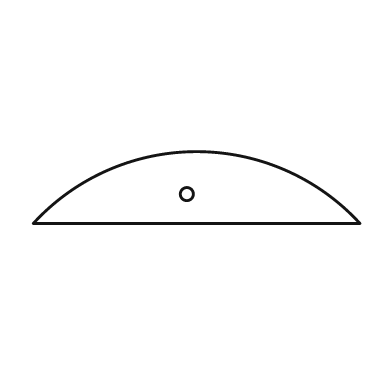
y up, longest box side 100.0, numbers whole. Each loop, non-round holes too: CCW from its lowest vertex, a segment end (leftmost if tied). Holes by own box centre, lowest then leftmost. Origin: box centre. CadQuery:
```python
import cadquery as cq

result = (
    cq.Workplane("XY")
    .moveTo(-50.0, -11.0)
    .lineTo(50.0, -11.0)
    .threePointArc((0.0, 11.0), (-50.0, -11.0))
    .close()
    .moveTo(-3.0, -2.0)
    .circle(2.0)
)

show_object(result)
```